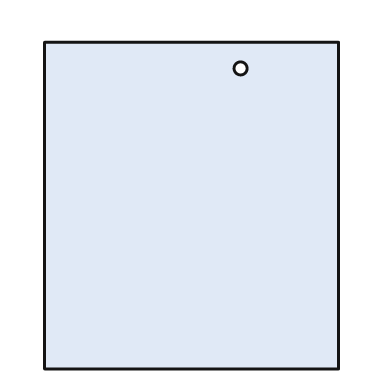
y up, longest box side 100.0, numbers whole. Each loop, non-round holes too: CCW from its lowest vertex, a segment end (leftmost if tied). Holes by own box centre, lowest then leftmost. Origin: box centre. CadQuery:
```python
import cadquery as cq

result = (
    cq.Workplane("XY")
    .moveTo(-45.0, -50.0)
    .lineTo(45.0, -50.0)
    .lineTo(45.0, 50.0)
    .lineTo(-45.0, 50.0)
    .close()
    .moveTo(15.0, 42.0)
    .circle(2.0)
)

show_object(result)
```